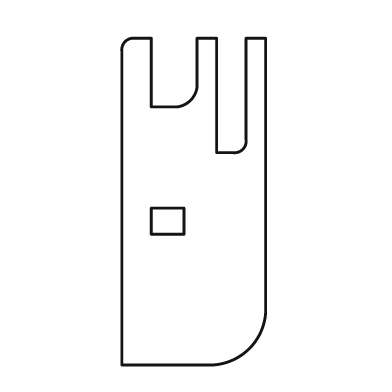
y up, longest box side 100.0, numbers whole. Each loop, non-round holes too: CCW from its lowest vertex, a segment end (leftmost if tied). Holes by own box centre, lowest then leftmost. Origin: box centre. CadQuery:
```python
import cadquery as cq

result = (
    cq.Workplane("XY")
    .moveTo(-22.0, -50.0)
    .lineTo(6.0, -50.0)
    .threePointArc((17.0, -45.0), (22.0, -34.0))
    .lineTo(22.0, 50.0)
    .lineTo(16.0, 50.0)
    .lineTo(16.0, 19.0)
    .threePointArc((15.0, 16.0), (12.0, 15.0))
    .lineTo(7.0, 15.0)
    .lineTo(7.0, 50.0)
    .lineTo(1.0, 50.0)
    .lineTo(1.0, 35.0)
    .threePointArc((-1.0, 31.0), (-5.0, 29.0))
    .lineTo(-13.0, 29.0)
    .lineTo(-13.0, 50.0)
    .lineTo(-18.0, 50.0)
    .threePointArc((-21.0, 49.0), (-22.0, 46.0))
    .close()
    .moveTo(-13.0, -10.0)
    .lineTo(-3.0, -10.0)
    .lineTo(-3.0, -2.0)
    .lineTo(-13.0, -2.0)
    .close()
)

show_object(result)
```